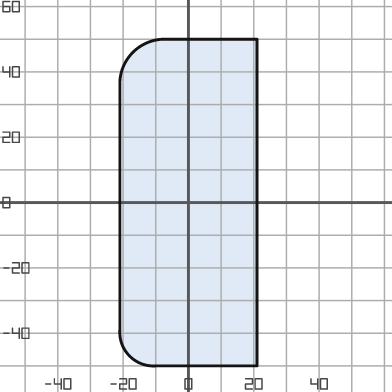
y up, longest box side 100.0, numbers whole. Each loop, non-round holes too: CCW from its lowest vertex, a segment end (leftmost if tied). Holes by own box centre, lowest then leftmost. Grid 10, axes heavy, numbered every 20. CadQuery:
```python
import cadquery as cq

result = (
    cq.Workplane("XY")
    .moveTo(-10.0, -50.0)
    .lineTo(21.0, -50.0)
    .lineTo(21.0, 50.0)
    .lineTo(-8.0, 50.0)
    .threePointArc((-17.0, 46.0), (-21.0, 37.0))
    .lineTo(-21.0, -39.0)
    .threePointArc((-18.0, -47.0), (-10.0, -50.0))
    .close()
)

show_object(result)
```